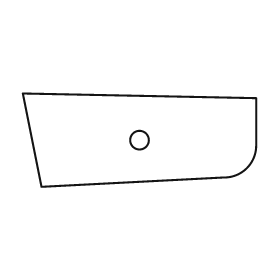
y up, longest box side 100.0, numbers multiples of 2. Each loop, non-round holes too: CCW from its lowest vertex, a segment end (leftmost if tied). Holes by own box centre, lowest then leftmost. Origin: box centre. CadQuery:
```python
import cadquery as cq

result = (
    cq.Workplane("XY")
    .moveTo(-42.0, -20.0)
    .lineTo(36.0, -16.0)
    .threePointArc((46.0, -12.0), (50.0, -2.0))
    .lineTo(50.0, 18.0)
    .lineTo(-50.0, 20.0)
    .close()
    .moveTo(0.0, 0.0)
    .circle(4.0)
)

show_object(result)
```